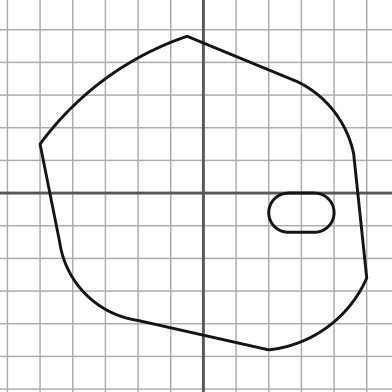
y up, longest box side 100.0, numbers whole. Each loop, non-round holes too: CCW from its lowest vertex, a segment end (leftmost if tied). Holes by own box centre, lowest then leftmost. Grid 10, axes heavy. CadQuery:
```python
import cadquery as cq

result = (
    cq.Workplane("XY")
    .moveTo(20.0, -48.0)
    .threePointArc((38.0, -41.0), (50.0, -26.0))
    .lineTo(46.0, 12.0)
    .threePointArc((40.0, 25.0), (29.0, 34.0))
    .lineTo(-5.0, 48.0)
    .threePointArc((-30.0, 35.0), (-50.0, 15.0))
    .lineTo(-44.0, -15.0)
    .threePointArc((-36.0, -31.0), (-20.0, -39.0))
    .close()
    .moveTo(26.0, -12.0)
    .lineTo(34.0, -12.0)
    .threePointArc((40.0, -6.0), (34.0, 0.0))
    .lineTo(26.0, 0.0)
    .threePointArc((20.0, -6.0), (26.0, -12.0))
    .close()
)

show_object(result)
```